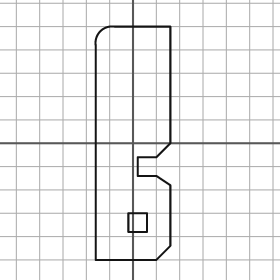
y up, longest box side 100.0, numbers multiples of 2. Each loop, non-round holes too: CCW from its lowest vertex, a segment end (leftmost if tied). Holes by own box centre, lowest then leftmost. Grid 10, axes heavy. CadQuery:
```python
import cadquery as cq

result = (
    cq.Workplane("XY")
    .moveTo(-16.0, -50.0)
    .lineTo(10.0, -50.0)
    .lineTo(16.0, -44.0)
    .lineTo(16.0, -18.0)
    .lineTo(10.0, -14.0)
    .lineTo(2.0, -14.0)
    .lineTo(2.0, -6.0)
    .lineTo(10.0, -6.0)
    .lineTo(16.0, 0.0)
    .lineTo(16.0, 50.0)
    .lineTo(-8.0, 50.0)
    .threePointArc((-14.0, 48.0), (-16.0, 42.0))
    .close()
    .moveTo(-2.0, -38.0)
    .lineTo(6.0, -38.0)
    .lineTo(6.0, -30.0)
    .lineTo(-2.0, -30.0)
    .close()
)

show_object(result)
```